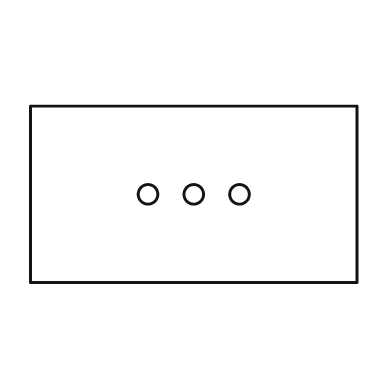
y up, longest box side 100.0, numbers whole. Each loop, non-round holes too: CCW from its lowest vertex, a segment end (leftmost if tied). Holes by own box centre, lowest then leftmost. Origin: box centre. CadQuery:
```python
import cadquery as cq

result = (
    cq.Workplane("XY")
    .moveTo(-50.0, -27.0)
    .lineTo(50.0, -27.0)
    .lineTo(50.0, 27.0)
    .lineTo(-50.0, 27.0)
    .close()
    .moveTo(-14.0, 0.0)
    .circle(3.0)
    .moveTo(0.0, 0.0)
    .circle(3.0)
    .moveTo(14.0, 0.0)
    .circle(3.0)
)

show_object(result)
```